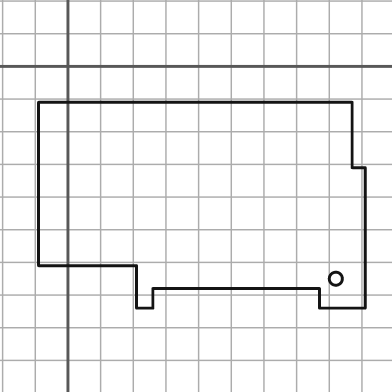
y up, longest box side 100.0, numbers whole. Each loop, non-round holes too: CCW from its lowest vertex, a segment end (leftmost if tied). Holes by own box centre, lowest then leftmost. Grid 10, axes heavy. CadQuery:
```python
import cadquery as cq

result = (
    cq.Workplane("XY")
    .moveTo(21.0, -74.0)
    .lineTo(26.0, -74.0)
    .lineTo(26.0, -68.0)
    .lineTo(77.0, -68.0)
    .lineTo(77.0, -74.0)
    .lineTo(91.0, -74.0)
    .lineTo(91.0, -31.0)
    .lineTo(87.0, -31.0)
    .lineTo(87.0, -11.0)
    .lineTo(-9.0, -11.0)
    .lineTo(-9.0, -61.0)
    .lineTo(21.0, -61.0)
    .close()
    .moveTo(82.0, -65.0)
    .circle(2.0)
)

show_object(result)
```